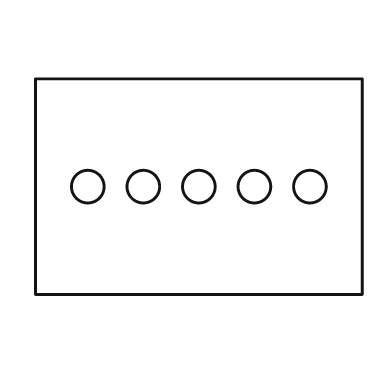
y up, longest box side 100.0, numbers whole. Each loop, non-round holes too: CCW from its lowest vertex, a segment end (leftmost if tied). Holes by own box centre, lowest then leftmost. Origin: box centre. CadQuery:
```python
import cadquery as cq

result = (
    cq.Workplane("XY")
    .moveTo(-50.0, -33.0)
    .lineTo(50.0, -33.0)
    .lineTo(50.0, 33.0)
    .lineTo(-50.0, 33.0)
    .close()
    .moveTo(-34.0, 0.0)
    .circle(5.0)
    .moveTo(-17.0, 0.0)
    .circle(5.0)
    .moveTo(0.0, 0.0)
    .circle(5.0)
    .moveTo(17.0, 0.0)
    .circle(5.0)
    .moveTo(34.0, 0.0)
    .circle(5.0)
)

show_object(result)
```